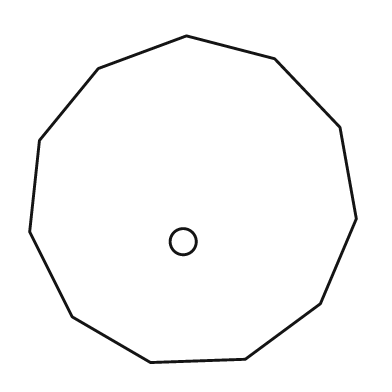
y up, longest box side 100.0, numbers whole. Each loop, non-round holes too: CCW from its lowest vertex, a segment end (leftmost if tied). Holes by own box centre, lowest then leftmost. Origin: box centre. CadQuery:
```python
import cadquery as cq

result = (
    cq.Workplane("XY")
    .moveTo(-13.0, -50.0)
    .lineTo(16.0, -49.0)
    .lineTo(39.0, -32.0)
    .lineTo(50.0, -6.0)
    .lineTo(45.0, 22.0)
    .lineTo(25.0, 43.0)
    .lineTo(-2.0, 50.0)
    .lineTo(-29.0, 40.0)
    .lineTo(-47.0, 18.0)
    .lineTo(-50.0, -10.0)
    .lineTo(-37.0, -36.0)
    .close()
    .moveTo(-3.0, -13.0)
    .circle(4.0)
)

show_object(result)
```